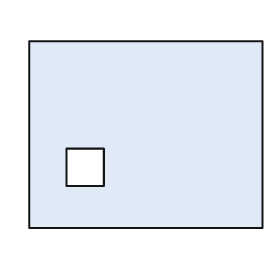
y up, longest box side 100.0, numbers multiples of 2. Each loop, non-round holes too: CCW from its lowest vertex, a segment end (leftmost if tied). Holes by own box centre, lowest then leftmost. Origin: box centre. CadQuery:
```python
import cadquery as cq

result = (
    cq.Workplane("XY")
    .moveTo(-50.0, -40.0)
    .lineTo(50.0, -40.0)
    .lineTo(50.0, 40.0)
    .lineTo(-50.0, 40.0)
    .close()
    .moveTo(-34.0, -22.0)
    .lineTo(-18.0, -22.0)
    .lineTo(-18.0, -6.0)
    .lineTo(-34.0, -6.0)
    .close()
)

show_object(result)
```